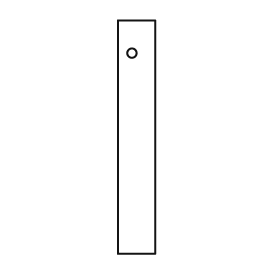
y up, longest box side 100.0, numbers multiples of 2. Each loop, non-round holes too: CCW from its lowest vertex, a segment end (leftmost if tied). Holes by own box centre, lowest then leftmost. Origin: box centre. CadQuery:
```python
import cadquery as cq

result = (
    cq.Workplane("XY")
    .moveTo(-8.0, -50.0)
    .lineTo(8.0, -50.0)
    .lineTo(8.0, 50.0)
    .lineTo(-8.0, 50.0)
    .close()
    .moveTo(-2.0, 36.0)
    .circle(2.0)
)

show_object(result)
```